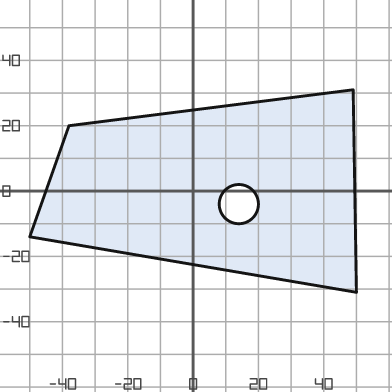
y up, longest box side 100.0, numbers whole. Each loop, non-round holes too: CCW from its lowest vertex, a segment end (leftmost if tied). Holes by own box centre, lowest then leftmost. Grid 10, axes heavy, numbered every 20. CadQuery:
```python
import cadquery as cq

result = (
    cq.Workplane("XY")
    .moveTo(50.0, -31.0)
    .lineTo(49.0, 31.0)
    .lineTo(-38.0, 20.0)
    .lineTo(-50.0, -14.0)
    .close()
    .moveTo(14.0, -4.0)
    .circle(6.0)
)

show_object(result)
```